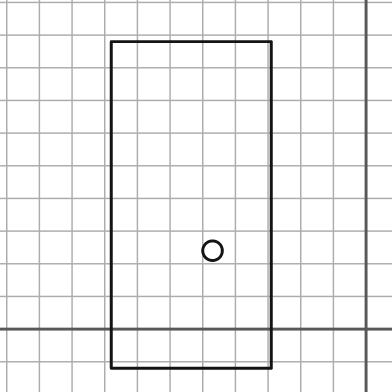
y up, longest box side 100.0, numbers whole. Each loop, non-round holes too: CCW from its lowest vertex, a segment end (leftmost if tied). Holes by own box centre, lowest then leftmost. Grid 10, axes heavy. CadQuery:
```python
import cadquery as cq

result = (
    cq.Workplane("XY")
    .moveTo(-78.0, -12.0)
    .lineTo(-29.0, -12.0)
    .lineTo(-29.0, 88.0)
    .lineTo(-78.0, 88.0)
    .close()
    .moveTo(-47.0, 24.0)
    .circle(3.0)
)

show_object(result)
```